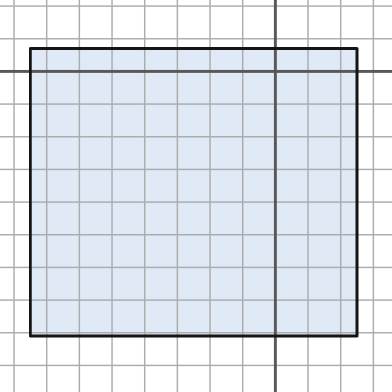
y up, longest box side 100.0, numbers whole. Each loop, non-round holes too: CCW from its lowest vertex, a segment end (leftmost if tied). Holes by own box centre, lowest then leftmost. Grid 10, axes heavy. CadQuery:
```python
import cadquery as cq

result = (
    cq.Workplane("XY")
    .moveTo(-75.0, -81.0)
    .lineTo(25.0, -81.0)
    .lineTo(25.0, 7.0)
    .lineTo(-75.0, 7.0)
    .close()
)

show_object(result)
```